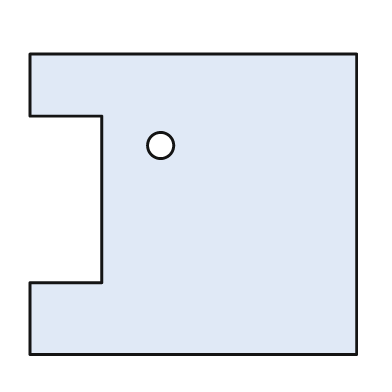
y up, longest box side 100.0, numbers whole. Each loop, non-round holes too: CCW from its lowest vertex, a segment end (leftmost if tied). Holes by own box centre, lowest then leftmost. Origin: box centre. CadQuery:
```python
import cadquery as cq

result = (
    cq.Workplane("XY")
    .moveTo(-50.0, -46.0)
    .lineTo(50.0, -46.0)
    .lineTo(50.0, 46.0)
    .lineTo(-50.0, 46.0)
    .lineTo(-50.0, 27.0)
    .lineTo(-28.0, 27.0)
    .lineTo(-28.0, -24.0)
    .lineTo(-50.0, -24.0)
    .close()
    .moveTo(-10.0, 18.0)
    .circle(4.0)
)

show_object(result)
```